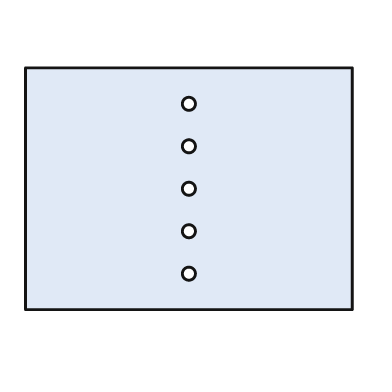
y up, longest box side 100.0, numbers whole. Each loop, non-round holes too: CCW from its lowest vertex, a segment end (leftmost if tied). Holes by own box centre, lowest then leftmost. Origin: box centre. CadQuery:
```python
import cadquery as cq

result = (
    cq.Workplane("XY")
    .moveTo(-50.0, -37.0)
    .lineTo(50.0, -37.0)
    .lineTo(50.0, 37.0)
    .lineTo(-50.0, 37.0)
    .close()
    .moveTo(0.0, -26.0)
    .circle(2.0)
    .moveTo(0.0, -13.0)
    .circle(2.0)
    .moveTo(0.0, 0.0)
    .circle(2.0)
    .moveTo(0.0, 13.0)
    .circle(2.0)
    .moveTo(0.0, 26.0)
    .circle(2.0)
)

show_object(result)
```